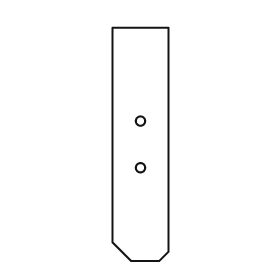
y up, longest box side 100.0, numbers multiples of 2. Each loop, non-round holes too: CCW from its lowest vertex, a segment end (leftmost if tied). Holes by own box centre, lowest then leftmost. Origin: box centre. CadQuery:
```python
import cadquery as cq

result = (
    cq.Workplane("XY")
    .moveTo(-4.0, -50.0)
    .lineTo(8.0, -50.0)
    .lineTo(12.0, -46.0)
    .lineTo(12.0, 50.0)
    .lineTo(-12.0, 50.0)
    .lineTo(-12.0, -42.0)
    .close()
    .moveTo(0.0, -10.0)
    .circle(2.0)
    .moveTo(0.0, 10.0)
    .circle(2.0)
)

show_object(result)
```